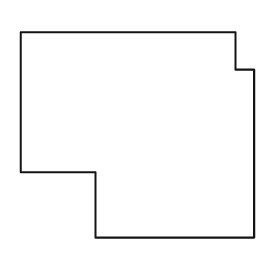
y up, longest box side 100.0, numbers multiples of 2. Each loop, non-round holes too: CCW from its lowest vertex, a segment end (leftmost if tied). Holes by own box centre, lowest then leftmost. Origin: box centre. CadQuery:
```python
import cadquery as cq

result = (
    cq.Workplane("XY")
    .moveTo(-18.0, -44.0)
    .lineTo(50.0, -44.0)
    .lineTo(50.0, 28.0)
    .lineTo(42.0, 28.0)
    .lineTo(42.0, 44.0)
    .lineTo(-50.0, 44.0)
    .lineTo(-50.0, -16.0)
    .lineTo(-18.0, -16.0)
    .close()
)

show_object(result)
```